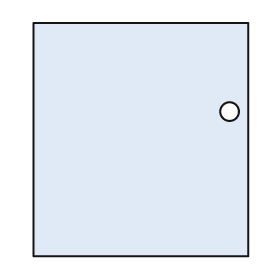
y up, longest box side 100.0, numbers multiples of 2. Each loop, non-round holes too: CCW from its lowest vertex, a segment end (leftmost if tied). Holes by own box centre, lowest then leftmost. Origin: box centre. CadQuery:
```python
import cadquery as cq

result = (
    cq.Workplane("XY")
    .moveTo(-46.0, -50.0)
    .lineTo(46.0, -50.0)
    .lineTo(46.0, 50.0)
    .lineTo(-46.0, 50.0)
    .close()
    .moveTo(38.0, 12.0)
    .circle(4.0)
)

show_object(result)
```